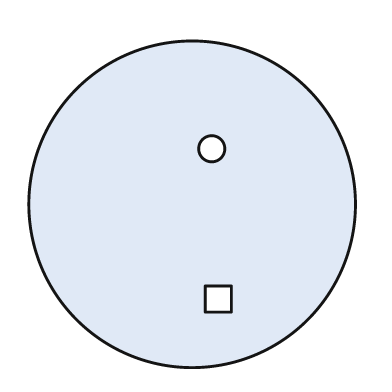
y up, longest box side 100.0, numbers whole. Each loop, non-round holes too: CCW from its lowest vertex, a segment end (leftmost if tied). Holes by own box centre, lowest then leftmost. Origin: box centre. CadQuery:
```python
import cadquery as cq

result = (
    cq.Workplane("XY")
    .moveTo(0.0, 0.0)
    .circle(50.0)
    .moveTo(4.0, -33.0)
    .lineTo(12.0, -33.0)
    .lineTo(12.0, -25.0)
    .lineTo(4.0, -25.0)
    .close()
    .moveTo(6.0, 17.0)
    .circle(4.0)
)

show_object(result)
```